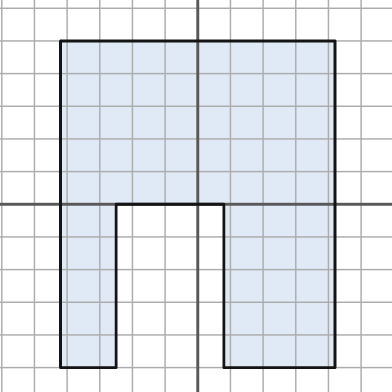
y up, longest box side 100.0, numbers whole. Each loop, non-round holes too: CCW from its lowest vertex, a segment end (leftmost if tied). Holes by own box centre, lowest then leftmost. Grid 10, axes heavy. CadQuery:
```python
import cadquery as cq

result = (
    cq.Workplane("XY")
    .moveTo(-42.0, -50.0)
    .lineTo(-25.0, -50.0)
    .lineTo(-25.0, 0.0)
    .lineTo(8.0, 0.0)
    .lineTo(8.0, -50.0)
    .lineTo(42.0, -50.0)
    .lineTo(42.0, 50.0)
    .lineTo(-42.0, 50.0)
    .close()
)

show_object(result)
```